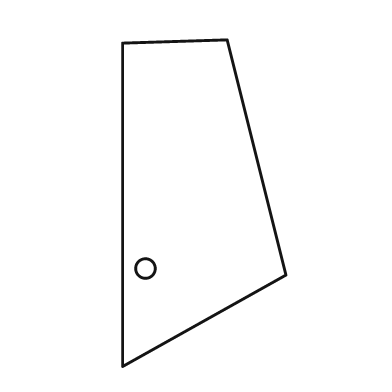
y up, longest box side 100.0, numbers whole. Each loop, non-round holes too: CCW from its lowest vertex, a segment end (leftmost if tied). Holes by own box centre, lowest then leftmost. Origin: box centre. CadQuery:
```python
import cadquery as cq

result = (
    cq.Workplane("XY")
    .moveTo(-25.0, -50.0)
    .lineTo(25.0, -22.0)
    .lineTo(7.0, 50.0)
    .lineTo(-25.0, 49.0)
    .close()
    .moveTo(-18.0, -20.0)
    .circle(3.0)
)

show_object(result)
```